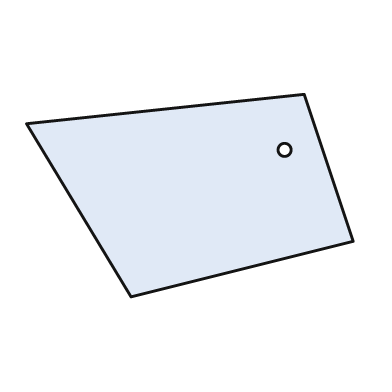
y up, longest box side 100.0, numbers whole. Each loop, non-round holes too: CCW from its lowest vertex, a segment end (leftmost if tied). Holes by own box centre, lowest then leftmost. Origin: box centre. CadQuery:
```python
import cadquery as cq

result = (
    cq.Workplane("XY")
    .moveTo(-18.0, -31.0)
    .lineTo(50.0, -14.0)
    .lineTo(35.0, 31.0)
    .lineTo(-50.0, 22.0)
    .close()
    .moveTo(29.0, 14.0)
    .circle(2.0)
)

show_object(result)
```